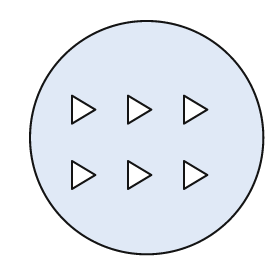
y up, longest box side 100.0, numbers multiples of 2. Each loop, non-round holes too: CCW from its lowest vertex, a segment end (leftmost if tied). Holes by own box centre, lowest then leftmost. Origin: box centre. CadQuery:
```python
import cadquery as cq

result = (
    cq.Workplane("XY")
    .moveTo(0.0, 0.0)
    .circle(50.0)
    .moveTo(-32.0, -22.0)
    .lineTo(-22.0, -16.0)
    .lineTo(-32.0, -10.0)
    .close()
    .moveTo(-8.0, -22.0)
    .lineTo(2.0, -16.0)
    .lineTo(-8.0, -10.0)
    .close()
    .moveTo(16.0, -22.0)
    .lineTo(26.0, -16.0)
    .lineTo(16.0, -10.0)
    .close()
    .moveTo(-32.0, 6.0)
    .lineTo(-22.0, 12.0)
    .lineTo(-32.0, 18.0)
    .close()
    .moveTo(-8.0, 6.0)
    .lineTo(2.0, 12.0)
    .lineTo(-8.0, 18.0)
    .close()
    .moveTo(16.0, 6.0)
    .lineTo(26.0, 12.0)
    .lineTo(16.0, 18.0)
    .close()
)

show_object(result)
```